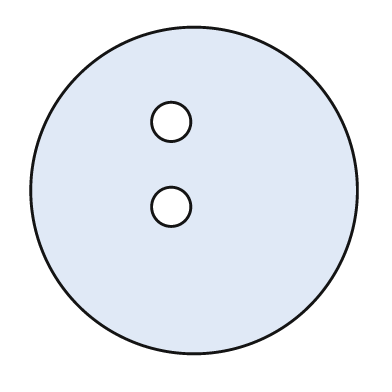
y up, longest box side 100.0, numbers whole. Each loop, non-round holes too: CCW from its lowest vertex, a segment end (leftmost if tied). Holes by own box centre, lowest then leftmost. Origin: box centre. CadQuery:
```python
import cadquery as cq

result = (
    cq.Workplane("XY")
    .moveTo(0.0, 0.0)
    .circle(50.0)
    .moveTo(-7.0, -5.0)
    .circle(6.0)
    .moveTo(-7.0, 21.0)
    .circle(6.0)
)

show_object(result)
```